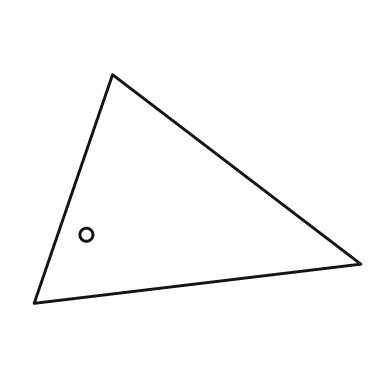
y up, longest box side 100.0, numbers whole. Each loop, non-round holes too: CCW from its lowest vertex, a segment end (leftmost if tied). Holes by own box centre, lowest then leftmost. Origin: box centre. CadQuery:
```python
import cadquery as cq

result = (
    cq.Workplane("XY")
    .moveTo(-50.0, -35.0)
    .lineTo(50.0, -23.0)
    .lineTo(-26.0, 35.0)
    .close()
    .moveTo(-34.0, -14.0)
    .circle(2.0)
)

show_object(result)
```